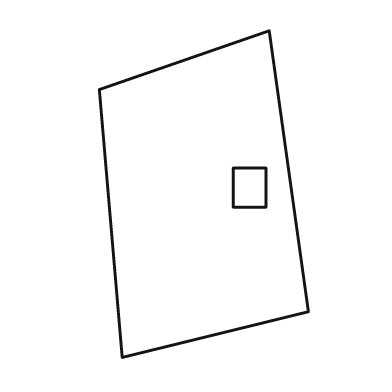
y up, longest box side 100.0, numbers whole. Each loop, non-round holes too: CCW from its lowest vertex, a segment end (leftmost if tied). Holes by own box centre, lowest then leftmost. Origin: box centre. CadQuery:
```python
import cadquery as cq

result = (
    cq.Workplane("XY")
    .moveTo(-25.0, -50.0)
    .lineTo(32.0, -36.0)
    .lineTo(20.0, 50.0)
    .lineTo(-32.0, 32.0)
    .close()
    .moveTo(9.0, -4.0)
    .lineTo(19.0, -4.0)
    .lineTo(19.0, 8.0)
    .lineTo(9.0, 8.0)
    .close()
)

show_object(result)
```